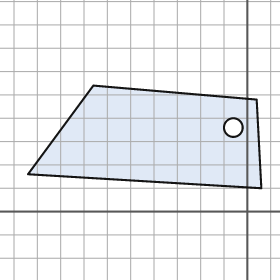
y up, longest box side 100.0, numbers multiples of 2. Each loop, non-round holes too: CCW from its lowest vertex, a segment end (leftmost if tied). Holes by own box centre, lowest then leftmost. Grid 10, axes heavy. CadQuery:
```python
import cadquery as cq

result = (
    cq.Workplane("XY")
    .moveTo(6.0, 10.0)
    .lineTo(4.0, 48.0)
    .lineTo(-66.0, 54.0)
    .lineTo(-94.0, 16.0)
    .close()
    .moveTo(-6.0, 36.0)
    .circle(4.0)
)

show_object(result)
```